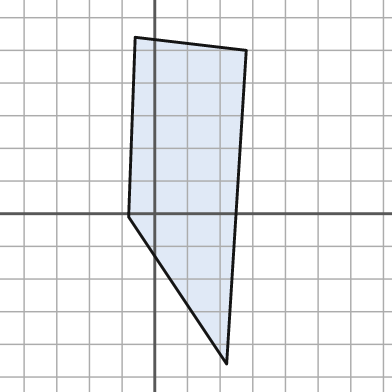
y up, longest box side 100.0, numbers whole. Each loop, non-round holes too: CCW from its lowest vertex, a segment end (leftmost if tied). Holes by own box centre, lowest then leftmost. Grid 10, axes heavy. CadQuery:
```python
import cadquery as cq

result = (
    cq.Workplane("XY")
    .moveTo(22.0, -46.0)
    .lineTo(28.0, 50.0)
    .lineTo(-6.0, 54.0)
    .lineTo(-8.0, -1.0)
    .close()
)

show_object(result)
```